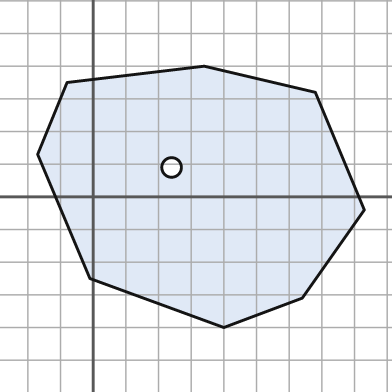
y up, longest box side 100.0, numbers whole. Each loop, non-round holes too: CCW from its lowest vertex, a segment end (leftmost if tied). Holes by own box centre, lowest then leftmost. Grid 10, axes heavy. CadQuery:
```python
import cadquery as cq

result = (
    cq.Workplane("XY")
    .moveTo(40.0, -40.0)
    .lineTo(64.0, -31.0)
    .lineTo(83.0, -4.0)
    .lineTo(68.0, 32.0)
    .lineTo(34.0, 40.0)
    .lineTo(-8.0, 35.0)
    .lineTo(-17.0, 13.0)
    .lineTo(-1.0, -25.0)
    .close()
    .moveTo(24.0, 9.0)
    .circle(3.0)
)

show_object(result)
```